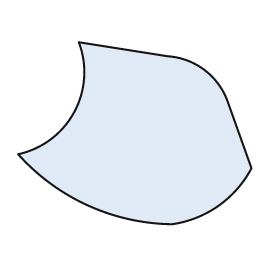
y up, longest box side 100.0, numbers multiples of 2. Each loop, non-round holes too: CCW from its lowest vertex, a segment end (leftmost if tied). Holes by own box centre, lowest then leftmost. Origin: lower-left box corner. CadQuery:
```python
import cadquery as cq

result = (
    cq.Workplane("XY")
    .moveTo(66.0, 0.0)
    .threePointArc((86.0, 8.0), (100.0, 24.0))
    .lineTo(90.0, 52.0)
    .threePointArc((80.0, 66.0), (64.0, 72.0))
    .lineTo(26.0, 78.0)
    .threePointArc((24.0, 48.0), (0.0, 30.0))
    .threePointArc((30.0, 8.0), (66.0, 0.0))
    .close()
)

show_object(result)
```